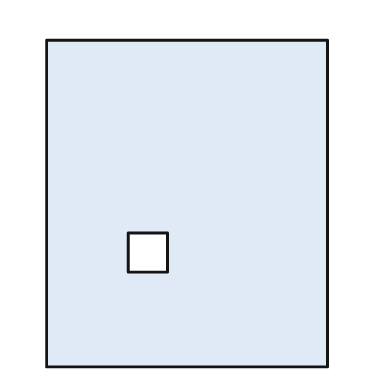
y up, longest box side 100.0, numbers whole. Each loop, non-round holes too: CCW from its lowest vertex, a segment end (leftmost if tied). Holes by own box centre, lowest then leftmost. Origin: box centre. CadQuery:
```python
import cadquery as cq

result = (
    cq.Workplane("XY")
    .moveTo(-43.0, -50.0)
    .lineTo(43.0, -50.0)
    .lineTo(43.0, 50.0)
    .lineTo(-43.0, 50.0)
    .close()
    .moveTo(-18.0, -21.0)
    .lineTo(-6.0, -21.0)
    .lineTo(-6.0, -9.0)
    .lineTo(-18.0, -9.0)
    .close()
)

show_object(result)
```